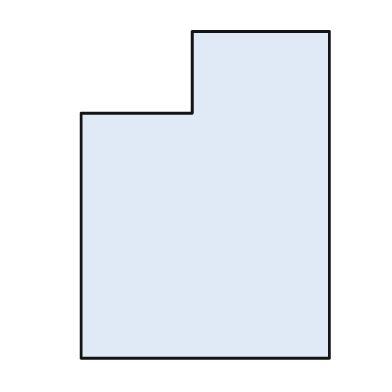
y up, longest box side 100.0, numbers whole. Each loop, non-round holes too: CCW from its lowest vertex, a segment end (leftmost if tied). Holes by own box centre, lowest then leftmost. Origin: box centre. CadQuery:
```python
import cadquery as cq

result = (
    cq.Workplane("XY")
    .moveTo(-38.0, -50.0)
    .lineTo(38.0, -50.0)
    .lineTo(38.0, 50.0)
    .lineTo(-4.0, 50.0)
    .lineTo(-4.0, 25.0)
    .lineTo(-38.0, 25.0)
    .close()
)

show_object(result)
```